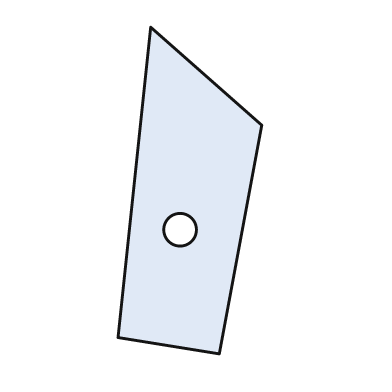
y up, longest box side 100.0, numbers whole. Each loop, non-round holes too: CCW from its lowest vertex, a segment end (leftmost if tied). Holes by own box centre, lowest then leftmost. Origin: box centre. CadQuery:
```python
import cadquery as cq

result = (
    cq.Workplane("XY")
    .moveTo(9.0, -50.0)
    .lineTo(22.0, 20.0)
    .lineTo(-12.0, 50.0)
    .lineTo(-22.0, -45.0)
    .close()
    .moveTo(-3.0, -12.0)
    .circle(5.0)
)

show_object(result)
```